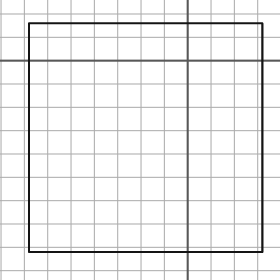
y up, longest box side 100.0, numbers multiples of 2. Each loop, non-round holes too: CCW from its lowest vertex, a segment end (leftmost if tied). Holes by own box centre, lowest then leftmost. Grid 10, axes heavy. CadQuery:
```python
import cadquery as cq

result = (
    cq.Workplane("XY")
    .moveTo(-68.0, -82.0)
    .lineTo(32.0, -82.0)
    .lineTo(32.0, 16.0)
    .lineTo(-68.0, 16.0)
    .close()
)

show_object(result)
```